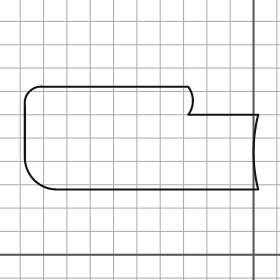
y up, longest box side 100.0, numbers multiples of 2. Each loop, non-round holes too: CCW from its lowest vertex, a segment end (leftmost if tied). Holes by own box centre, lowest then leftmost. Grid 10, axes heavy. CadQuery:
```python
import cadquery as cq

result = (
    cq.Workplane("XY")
    .moveTo(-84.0, 28.0)
    .lineTo(2.0, 28.0)
    .threePointArc((0.0, 44.0), (2.0, 60.0))
    .lineTo(-28.0, 60.0)
    .threePointArc((-26.0, 66.0), (-28.0, 72.0))
    .lineTo(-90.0, 72.0)
    .threePointArc((-96.0, 70.0), (-98.0, 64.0))
    .lineTo(-98.0, 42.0)
    .threePointArc((-94.0, 32.0), (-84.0, 28.0))
    .close()
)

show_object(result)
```